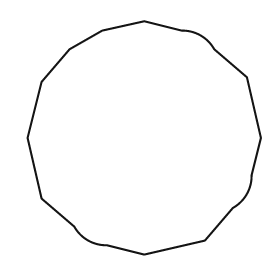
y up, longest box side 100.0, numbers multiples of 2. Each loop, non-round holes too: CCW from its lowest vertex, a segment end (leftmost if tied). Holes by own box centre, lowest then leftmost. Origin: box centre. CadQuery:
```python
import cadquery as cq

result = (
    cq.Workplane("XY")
    .moveTo(0.0, -50.0)
    .lineTo(26.0, -44.0)
    .lineTo(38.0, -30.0)
    .threePointArc((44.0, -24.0), (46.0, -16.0))
    .lineTo(50.0, 0.0)
    .lineTo(44.0, 26.0)
    .lineTo(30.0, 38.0)
    .threePointArc((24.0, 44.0), (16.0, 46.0))
    .lineTo(0.0, 50.0)
    .lineTo(-18.0, 46.0)
    .lineTo(-32.0, 38.0)
    .lineTo(-44.0, 24.0)
    .lineTo(-50.0, 0.0)
    .lineTo(-44.0, -26.0)
    .lineTo(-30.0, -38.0)
    .threePointArc((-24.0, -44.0), (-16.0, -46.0))
    .close()
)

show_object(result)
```